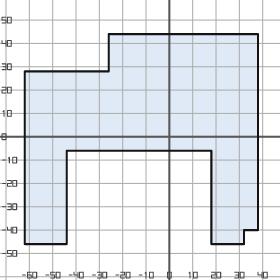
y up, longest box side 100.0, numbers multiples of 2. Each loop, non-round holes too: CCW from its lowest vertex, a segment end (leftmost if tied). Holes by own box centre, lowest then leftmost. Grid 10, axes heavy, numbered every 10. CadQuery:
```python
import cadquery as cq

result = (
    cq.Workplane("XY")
    .moveTo(-62.0, -46.0)
    .lineTo(-44.0, -46.0)
    .lineTo(-44.0, -6.0)
    .lineTo(18.0, -6.0)
    .lineTo(18.0, -46.0)
    .lineTo(32.0, -46.0)
    .lineTo(32.0, -40.0)
    .lineTo(38.0, -40.0)
    .lineTo(38.0, 44.0)
    .lineTo(-26.0, 44.0)
    .lineTo(-26.0, 28.0)
    .lineTo(-62.0, 28.0)
    .close()
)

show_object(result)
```